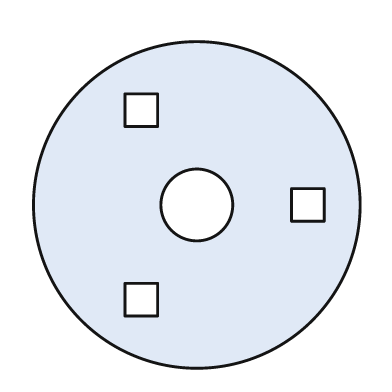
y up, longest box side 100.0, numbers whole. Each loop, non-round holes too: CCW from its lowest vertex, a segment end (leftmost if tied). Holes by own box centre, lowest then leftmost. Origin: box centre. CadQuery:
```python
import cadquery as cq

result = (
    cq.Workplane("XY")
    .moveTo(0.0, 0.0)
    .circle(50.0)
    .moveTo(-22.0, -34.0)
    .lineTo(-12.0, -34.0)
    .lineTo(-12.0, -24.0)
    .lineTo(-22.0, -24.0)
    .close()
    .moveTo(0.0, 0.0)
    .circle(11.0)
    .moveTo(29.0, -5.0)
    .lineTo(39.0, -5.0)
    .lineTo(39.0, 5.0)
    .lineTo(29.0, 5.0)
    .close()
    .moveTo(-22.0, 24.0)
    .lineTo(-12.0, 24.0)
    .lineTo(-12.0, 34.0)
    .lineTo(-22.0, 34.0)
    .close()
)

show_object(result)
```